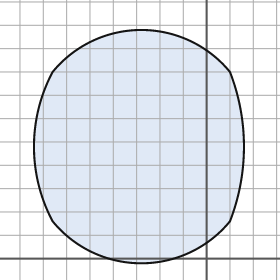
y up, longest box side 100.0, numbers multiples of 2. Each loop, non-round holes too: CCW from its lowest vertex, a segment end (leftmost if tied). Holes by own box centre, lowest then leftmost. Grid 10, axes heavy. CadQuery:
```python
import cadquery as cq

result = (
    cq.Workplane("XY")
    .moveTo(-66.0, 16.0)
    .threePointArc((-28.0, -2.0), (10.0, 16.0))
    .threePointArc((16.0, 48.0), (10.0, 80.0))
    .threePointArc((-28.0, 98.0), (-66.0, 80.0))
    .threePointArc((-74.0, 48.0), (-66.0, 16.0))
    .close()
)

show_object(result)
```